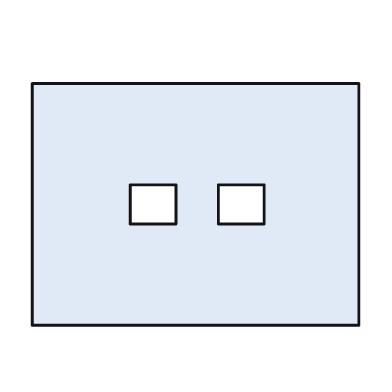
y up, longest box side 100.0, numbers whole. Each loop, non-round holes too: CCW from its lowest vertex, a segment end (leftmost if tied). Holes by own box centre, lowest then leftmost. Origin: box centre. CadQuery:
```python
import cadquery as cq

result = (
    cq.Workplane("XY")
    .moveTo(-50.0, -37.0)
    .lineTo(50.0, -37.0)
    .lineTo(50.0, 37.0)
    .lineTo(-50.0, 37.0)
    .close()
    .moveTo(-20.0, -6.0)
    .lineTo(-6.0, -6.0)
    .lineTo(-6.0, 6.0)
    .lineTo(-20.0, 6.0)
    .close()
    .moveTo(7.0, -6.0)
    .lineTo(21.0, -6.0)
    .lineTo(21.0, 6.0)
    .lineTo(7.0, 6.0)
    .close()
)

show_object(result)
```